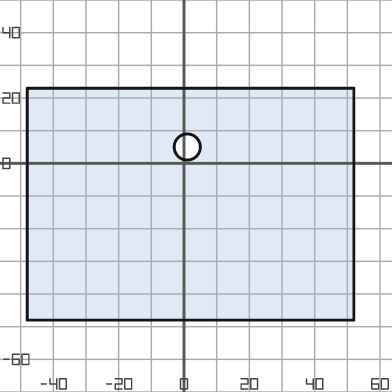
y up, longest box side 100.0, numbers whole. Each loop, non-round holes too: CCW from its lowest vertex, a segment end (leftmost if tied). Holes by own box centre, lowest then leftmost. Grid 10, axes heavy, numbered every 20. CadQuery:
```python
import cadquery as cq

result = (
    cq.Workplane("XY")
    .moveTo(-48.0, -48.0)
    .lineTo(52.0, -48.0)
    .lineTo(52.0, 23.0)
    .lineTo(-48.0, 23.0)
    .close()
    .moveTo(1.0, 5.0)
    .circle(4.0)
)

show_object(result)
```